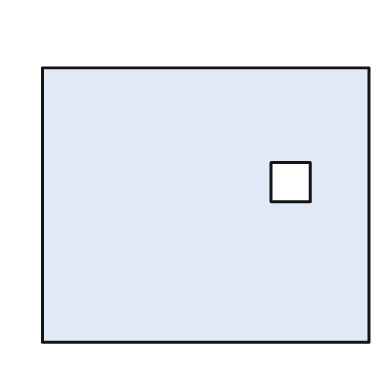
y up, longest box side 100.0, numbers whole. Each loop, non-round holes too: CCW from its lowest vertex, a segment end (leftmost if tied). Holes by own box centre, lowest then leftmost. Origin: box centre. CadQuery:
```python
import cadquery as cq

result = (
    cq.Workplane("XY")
    .moveTo(-50.0, -42.0)
    .lineTo(50.0, -42.0)
    .lineTo(50.0, 42.0)
    .lineTo(-50.0, 42.0)
    .close()
    .moveTo(20.0, 1.0)
    .lineTo(32.0, 1.0)
    .lineTo(32.0, 13.0)
    .lineTo(20.0, 13.0)
    .close()
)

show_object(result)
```